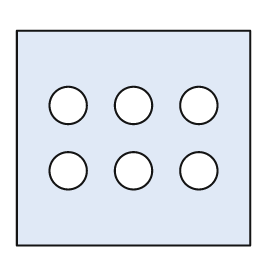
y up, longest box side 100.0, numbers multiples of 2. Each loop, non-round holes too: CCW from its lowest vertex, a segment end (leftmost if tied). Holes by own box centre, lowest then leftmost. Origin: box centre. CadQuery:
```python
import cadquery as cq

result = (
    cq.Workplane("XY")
    .moveTo(-50.0, -46.0)
    .lineTo(50.0, -46.0)
    .lineTo(50.0, 46.0)
    .lineTo(-50.0, 46.0)
    .close()
    .moveTo(-28.0, -14.0)
    .circle(8.0)
    .moveTo(0.0, -14.0)
    .circle(8.0)
    .moveTo(28.0, -14.0)
    .circle(8.0)
    .moveTo(-28.0, 14.0)
    .circle(8.0)
    .moveTo(0.0, 14.0)
    .circle(8.0)
    .moveTo(28.0, 14.0)
    .circle(8.0)
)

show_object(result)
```